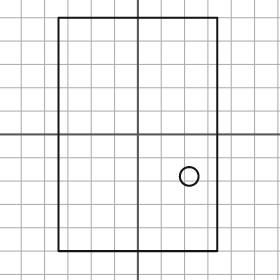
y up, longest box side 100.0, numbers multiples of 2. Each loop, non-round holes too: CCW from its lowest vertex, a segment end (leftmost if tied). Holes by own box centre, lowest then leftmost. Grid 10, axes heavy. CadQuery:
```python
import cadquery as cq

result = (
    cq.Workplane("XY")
    .moveTo(-34.0, -50.0)
    .lineTo(34.0, -50.0)
    .lineTo(34.0, 50.0)
    .lineTo(-34.0, 50.0)
    .close()
    .moveTo(22.0, -18.0)
    .circle(4.0)
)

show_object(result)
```